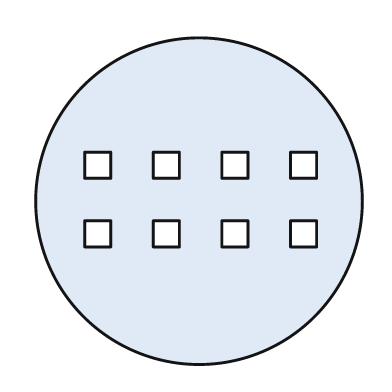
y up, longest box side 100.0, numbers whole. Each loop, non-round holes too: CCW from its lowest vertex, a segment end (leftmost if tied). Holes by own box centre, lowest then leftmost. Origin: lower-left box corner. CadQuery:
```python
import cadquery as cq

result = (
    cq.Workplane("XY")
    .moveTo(50.0, 50.0)
    .circle(50.0)
    .moveTo(15.0, 36.0)
    .lineTo(23.0, 36.0)
    .lineTo(23.0, 44.0)
    .lineTo(15.0, 44.0)
    .close()
    .moveTo(36.0, 36.0)
    .lineTo(44.0, 36.0)
    .lineTo(44.0, 44.0)
    .lineTo(36.0, 44.0)
    .close()
    .moveTo(57.0, 36.0)
    .lineTo(65.0, 36.0)
    .lineTo(65.0, 44.0)
    .lineTo(57.0, 44.0)
    .close()
    .moveTo(78.0, 36.0)
    .lineTo(86.0, 36.0)
    .lineTo(86.0, 44.0)
    .lineTo(78.0, 44.0)
    .close()
    .moveTo(15.0, 57.0)
    .lineTo(23.0, 57.0)
    .lineTo(23.0, 65.0)
    .lineTo(15.0, 65.0)
    .close()
    .moveTo(36.0, 57.0)
    .lineTo(44.0, 57.0)
    .lineTo(44.0, 65.0)
    .lineTo(36.0, 65.0)
    .close()
    .moveTo(57.0, 57.0)
    .lineTo(65.0, 57.0)
    .lineTo(65.0, 65.0)
    .lineTo(57.0, 65.0)
    .close()
    .moveTo(78.0, 57.0)
    .lineTo(86.0, 57.0)
    .lineTo(86.0, 65.0)
    .lineTo(78.0, 65.0)
    .close()
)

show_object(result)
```